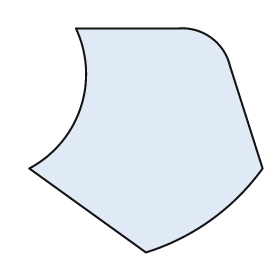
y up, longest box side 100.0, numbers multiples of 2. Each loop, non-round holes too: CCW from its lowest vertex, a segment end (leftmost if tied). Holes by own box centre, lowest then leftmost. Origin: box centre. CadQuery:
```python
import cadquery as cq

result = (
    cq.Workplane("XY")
    .moveTo(0.0, -48.0)
    .threePointArc((28.0, -34.0), (50.0, -12.0))
    .lineTo(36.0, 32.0)
    .threePointArc((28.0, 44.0), (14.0, 48.0))
    .lineTo(-30.0, 48.0)
    .threePointArc((-28.0, 14.0), (-50.0, -12.0))
    .close()
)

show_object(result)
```